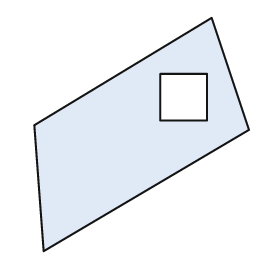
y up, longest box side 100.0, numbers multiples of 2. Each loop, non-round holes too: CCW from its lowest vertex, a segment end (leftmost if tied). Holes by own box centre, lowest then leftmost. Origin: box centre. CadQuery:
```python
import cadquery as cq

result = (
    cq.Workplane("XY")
    .moveTo(-42.0, -50.0)
    .lineTo(46.0, 2.0)
    .lineTo(30.0, 50.0)
    .lineTo(-46.0, 4.0)
    .close()
    .moveTo(8.0, 6.0)
    .lineTo(28.0, 6.0)
    .lineTo(28.0, 26.0)
    .lineTo(8.0, 26.0)
    .close()
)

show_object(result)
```